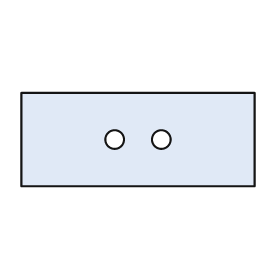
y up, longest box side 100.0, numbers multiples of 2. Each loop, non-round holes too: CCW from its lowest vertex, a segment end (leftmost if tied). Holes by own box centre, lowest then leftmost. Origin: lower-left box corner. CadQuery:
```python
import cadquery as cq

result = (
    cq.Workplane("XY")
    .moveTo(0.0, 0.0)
    .lineTo(100.0, 0.0)
    .lineTo(100.0, 40.0)
    .lineTo(0.0, 40.0)
    .close()
    .moveTo(40.0, 20.0)
    .circle(4.0)
    .moveTo(60.0, 20.0)
    .circle(4.0)
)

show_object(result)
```